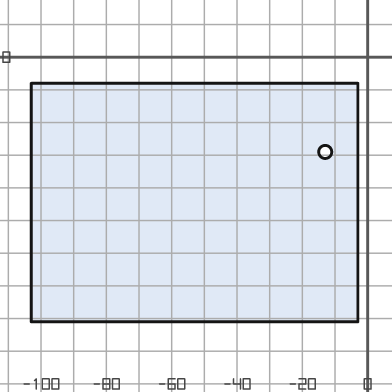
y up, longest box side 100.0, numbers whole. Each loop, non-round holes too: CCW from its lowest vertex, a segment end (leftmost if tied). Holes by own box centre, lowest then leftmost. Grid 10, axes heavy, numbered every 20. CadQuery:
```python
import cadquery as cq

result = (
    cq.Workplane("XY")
    .moveTo(-103.0, -81.0)
    .lineTo(-3.0, -81.0)
    .lineTo(-3.0, -8.0)
    .lineTo(-103.0, -8.0)
    .close()
    .moveTo(-13.0, -29.0)
    .circle(2.0)
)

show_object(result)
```